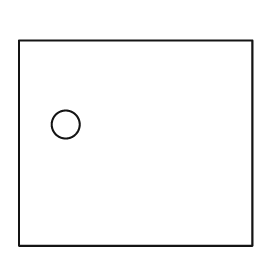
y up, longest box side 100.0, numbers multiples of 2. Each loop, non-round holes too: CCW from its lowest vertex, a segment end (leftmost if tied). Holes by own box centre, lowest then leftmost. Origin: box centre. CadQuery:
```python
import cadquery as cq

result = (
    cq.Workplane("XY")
    .moveTo(-50.0, -44.0)
    .lineTo(50.0, -44.0)
    .lineTo(50.0, 44.0)
    .lineTo(-50.0, 44.0)
    .close()
    .moveTo(-30.0, 8.0)
    .circle(6.0)
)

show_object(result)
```